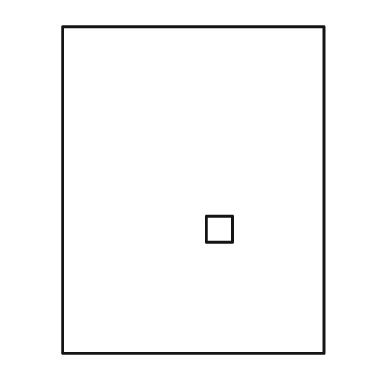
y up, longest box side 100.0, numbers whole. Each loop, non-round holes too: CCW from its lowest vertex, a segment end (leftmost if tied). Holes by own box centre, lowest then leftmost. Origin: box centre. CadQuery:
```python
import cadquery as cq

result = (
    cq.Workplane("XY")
    .moveTo(-40.0, -50.0)
    .lineTo(40.0, -50.0)
    .lineTo(40.0, 50.0)
    .lineTo(-40.0, 50.0)
    .close()
    .moveTo(4.0, -16.0)
    .lineTo(12.0, -16.0)
    .lineTo(12.0, -8.0)
    .lineTo(4.0, -8.0)
    .close()
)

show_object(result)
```